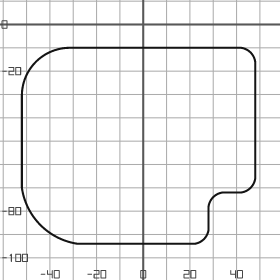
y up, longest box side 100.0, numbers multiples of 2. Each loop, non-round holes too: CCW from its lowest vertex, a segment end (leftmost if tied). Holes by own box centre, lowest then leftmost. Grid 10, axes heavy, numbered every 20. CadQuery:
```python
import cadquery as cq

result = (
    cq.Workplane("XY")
    .moveTo(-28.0, -94.0)
    .lineTo(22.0, -94.0)
    .threePointArc((26.0, -92.0), (28.0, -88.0))
    .lineTo(28.0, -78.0)
    .threePointArc((30.0, -74.0), (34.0, -72.0))
    .lineTo(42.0, -72.0)
    .threePointArc((46.0, -70.0), (48.0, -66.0))
    .lineTo(48.0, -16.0)
    .threePointArc((46.0, -12.0), (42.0, -10.0))
    .lineTo(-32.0, -10.0)
    .threePointArc((-46.0, -16.0), (-52.0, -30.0))
    .lineTo(-52.0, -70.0)
    .threePointArc((-44.0, -86.0), (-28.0, -94.0))
    .close()
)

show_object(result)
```